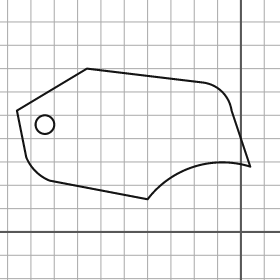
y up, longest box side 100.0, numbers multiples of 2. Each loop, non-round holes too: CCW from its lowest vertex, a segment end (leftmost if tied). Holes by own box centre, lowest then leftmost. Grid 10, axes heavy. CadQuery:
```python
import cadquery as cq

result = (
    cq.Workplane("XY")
    .moveTo(-40.0, 14.0)
    .threePointArc((-20.0, 28.0), (4.0, 28.0))
    .lineTo(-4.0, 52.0)
    .threePointArc((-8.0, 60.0), (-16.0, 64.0))
    .lineTo(-66.0, 70.0)
    .lineTo(-96.0, 52.0)
    .lineTo(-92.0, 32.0)
    .threePointArc((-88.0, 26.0), (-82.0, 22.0))
    .close()
    .moveTo(-84.0, 46.0)
    .circle(4.0)
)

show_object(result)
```